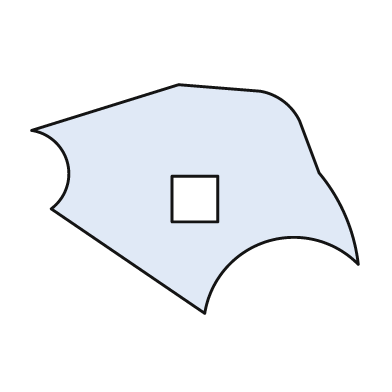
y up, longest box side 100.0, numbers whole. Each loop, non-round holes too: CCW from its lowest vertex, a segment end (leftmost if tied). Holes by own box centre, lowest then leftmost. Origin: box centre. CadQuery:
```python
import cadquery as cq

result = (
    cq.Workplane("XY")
    .moveTo(3.0, -35.0)
    .threePointArc((22.0, -13.0), (50.0, -20.0))
    .threePointArc((46.0, -5.0), (38.0, 8.0))
    .lineTo(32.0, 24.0)
    .threePointArc((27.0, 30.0), (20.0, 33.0))
    .lineTo(-5.0, 35.0)
    .lineTo(-50.0, 21.0)
    .threePointArc((-39.0, 11.0), (-44.0, -3.0))
    .close()
    .moveTo(-7.0, -7.0)
    .lineTo(7.0, -7.0)
    .lineTo(7.0, 7.0)
    .lineTo(-7.0, 7.0)
    .close()
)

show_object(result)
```